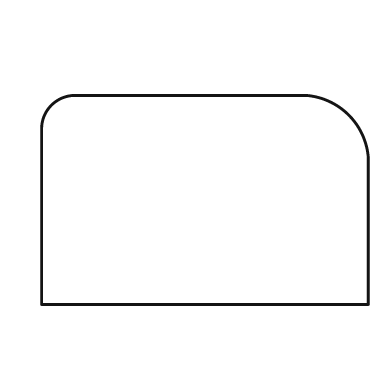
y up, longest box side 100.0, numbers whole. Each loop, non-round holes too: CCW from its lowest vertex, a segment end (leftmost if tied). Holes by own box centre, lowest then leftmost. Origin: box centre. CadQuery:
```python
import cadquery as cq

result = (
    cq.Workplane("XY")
    .moveTo(-50.0, -32.0)
    .lineTo(50.0, -32.0)
    .lineTo(50.0, 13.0)
    .threePointArc((44.0, 26.0), (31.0, 32.0))
    .lineTo(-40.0, 32.0)
    .threePointArc((-47.0, 29.0), (-50.0, 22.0))
    .close()
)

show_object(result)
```